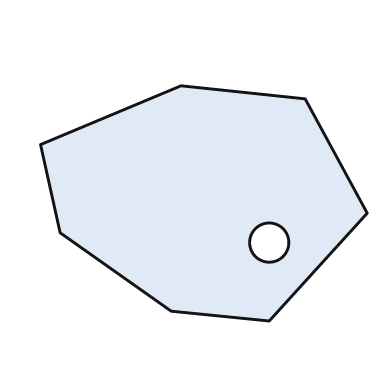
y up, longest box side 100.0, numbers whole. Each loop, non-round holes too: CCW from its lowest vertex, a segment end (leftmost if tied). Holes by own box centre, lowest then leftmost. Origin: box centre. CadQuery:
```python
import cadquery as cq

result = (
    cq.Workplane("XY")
    .moveTo(20.0, -36.0)
    .lineTo(50.0, -3.0)
    .lineTo(31.0, 32.0)
    .lineTo(-7.0, 36.0)
    .lineTo(-50.0, 18.0)
    .lineTo(-44.0, -9.0)
    .lineTo(-10.0, -33.0)
    .close()
    .moveTo(20.0, -12.0)
    .circle(6.0)
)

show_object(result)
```